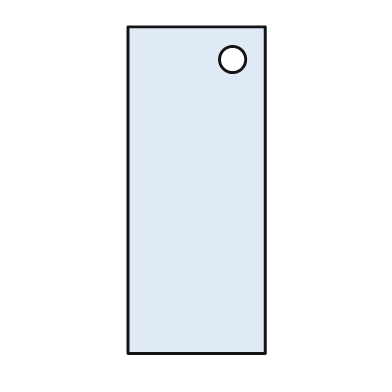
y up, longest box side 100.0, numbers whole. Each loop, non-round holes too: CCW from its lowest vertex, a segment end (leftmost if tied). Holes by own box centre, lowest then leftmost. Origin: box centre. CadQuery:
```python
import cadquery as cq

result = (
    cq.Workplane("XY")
    .moveTo(-21.0, -50.0)
    .lineTo(21.0, -50.0)
    .lineTo(21.0, 50.0)
    .lineTo(-21.0, 50.0)
    .close()
    .moveTo(11.0, 40.0)
    .circle(4.0)
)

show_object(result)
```